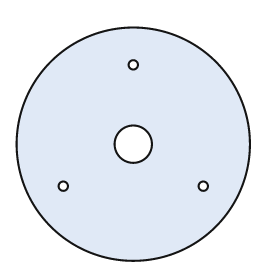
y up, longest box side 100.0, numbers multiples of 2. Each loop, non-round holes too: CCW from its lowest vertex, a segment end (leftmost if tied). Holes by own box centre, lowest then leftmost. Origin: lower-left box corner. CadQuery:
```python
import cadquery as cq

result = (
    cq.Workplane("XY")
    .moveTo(50.0, 50.0)
    .circle(50.0)
    .moveTo(20.0, 32.0)
    .circle(2.0)
    .moveTo(80.0, 32.0)
    .circle(2.0)
    .moveTo(50.0, 50.0)
    .circle(8.0)
    .moveTo(50.0, 84.0)
    .circle(2.0)
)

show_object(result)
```